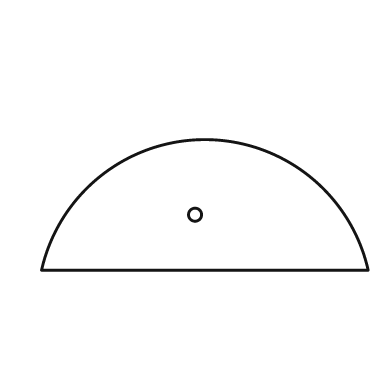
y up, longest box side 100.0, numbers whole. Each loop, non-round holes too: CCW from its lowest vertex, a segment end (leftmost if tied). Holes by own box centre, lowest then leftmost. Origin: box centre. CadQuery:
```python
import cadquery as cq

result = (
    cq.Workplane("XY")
    .moveTo(-50.0, -20.0)
    .lineTo(50.0, -20.0)
    .threePointArc((0.0, 20.0), (-50.0, -20.0))
    .close()
    .moveTo(-3.0, -3.0)
    .circle(2.0)
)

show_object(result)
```